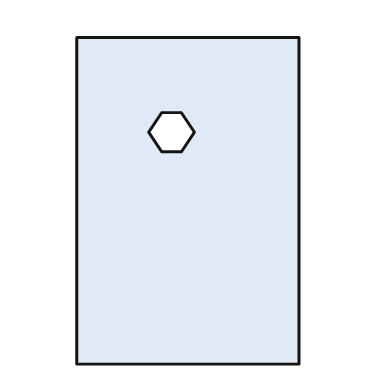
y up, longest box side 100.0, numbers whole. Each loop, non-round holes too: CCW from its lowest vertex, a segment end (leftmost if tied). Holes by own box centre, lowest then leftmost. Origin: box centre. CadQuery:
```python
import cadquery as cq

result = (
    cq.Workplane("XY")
    .moveTo(-34.0, -50.0)
    .lineTo(34.0, -50.0)
    .lineTo(34.0, 50.0)
    .lineTo(-34.0, 50.0)
    .close()
    .moveTo(-8.0, 15.0)
    .lineTo(-2.0, 15.0)
    .lineTo(2.0, 21.0)
    .lineTo(-2.0, 27.0)
    .lineTo(-8.0, 27.0)
    .lineTo(-12.0, 21.0)
    .close()
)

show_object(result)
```